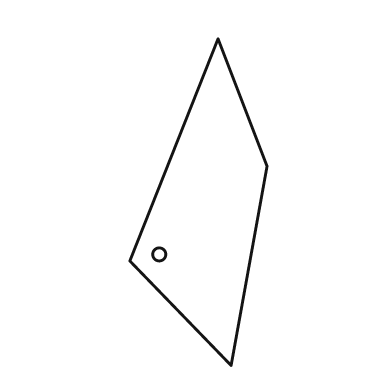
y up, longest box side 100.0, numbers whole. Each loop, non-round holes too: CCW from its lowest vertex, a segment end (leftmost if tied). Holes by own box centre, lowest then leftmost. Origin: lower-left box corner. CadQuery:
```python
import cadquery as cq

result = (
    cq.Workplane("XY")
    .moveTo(31.0, 0.0)
    .lineTo(42.0, 61.0)
    .lineTo(27.0, 100.0)
    .lineTo(0.0, 32.0)
    .close()
    .moveTo(9.0, 34.0)
    .circle(2.0)
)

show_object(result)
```